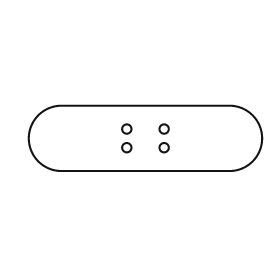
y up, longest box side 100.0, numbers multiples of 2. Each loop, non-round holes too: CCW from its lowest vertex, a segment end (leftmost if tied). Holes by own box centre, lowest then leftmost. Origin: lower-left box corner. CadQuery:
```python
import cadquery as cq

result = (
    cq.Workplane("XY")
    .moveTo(14.0, 0.0)
    .lineTo(86.0, 0.0)
    .threePointArc((100.0, 14.0), (86.0, 28.0))
    .lineTo(14.0, 28.0)
    .threePointArc((0.0, 14.0), (14.0, 0.0))
    .close()
    .moveTo(42.0, 10.0)
    .circle(2.0)
    .moveTo(58.0, 10.0)
    .circle(2.0)
    .moveTo(42.0, 18.0)
    .circle(2.0)
    .moveTo(58.0, 18.0)
    .circle(2.0)
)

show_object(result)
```